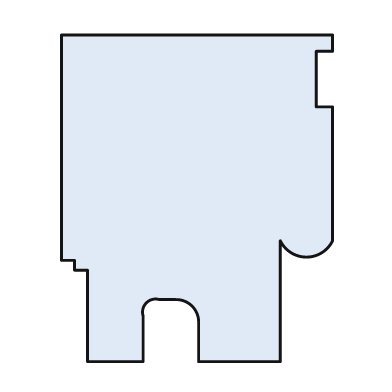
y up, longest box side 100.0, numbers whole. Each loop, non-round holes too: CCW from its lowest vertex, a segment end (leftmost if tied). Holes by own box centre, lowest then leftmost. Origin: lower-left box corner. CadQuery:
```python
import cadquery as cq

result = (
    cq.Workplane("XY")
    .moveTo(8.0, 0.0)
    .lineTo(25.0, 0.0)
    .lineTo(25.0, 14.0)
    .threePointArc((26.0, 18.0), (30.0, 19.0))
    .lineTo(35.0, 19.0)
    .threePointArc((40.0, 17.0), (42.0, 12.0))
    .lineTo(42.0, 0.0)
    .lineTo(67.0, 0.0)
    .lineTo(67.0, 37.0)
    .threePointArc((75.0, 32.0), (83.0, 37.0))
    .lineTo(83.0, 78.0)
    .lineTo(78.0, 78.0)
    .lineTo(78.0, 95.0)
    .lineTo(83.0, 95.0)
    .lineTo(83.0, 100.0)
    .lineTo(0.0, 100.0)
    .lineTo(0.0, 31.0)
    .lineTo(4.0, 31.0)
    .lineTo(4.0, 28.0)
    .lineTo(8.0, 28.0)
    .close()
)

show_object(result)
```